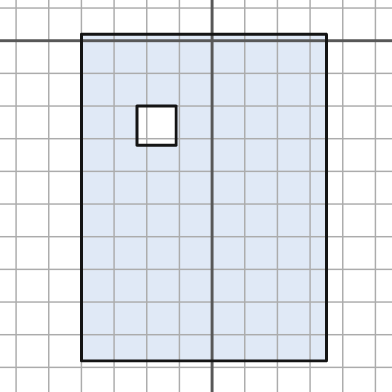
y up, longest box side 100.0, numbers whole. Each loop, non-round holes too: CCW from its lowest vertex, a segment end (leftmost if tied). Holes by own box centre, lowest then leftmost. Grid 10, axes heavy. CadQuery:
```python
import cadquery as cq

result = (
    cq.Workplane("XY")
    .moveTo(-40.0, -98.0)
    .lineTo(35.0, -98.0)
    .lineTo(35.0, 2.0)
    .lineTo(-40.0, 2.0)
    .close()
    .moveTo(-23.0, -32.0)
    .lineTo(-11.0, -32.0)
    .lineTo(-11.0, -20.0)
    .lineTo(-23.0, -20.0)
    .close()
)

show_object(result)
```